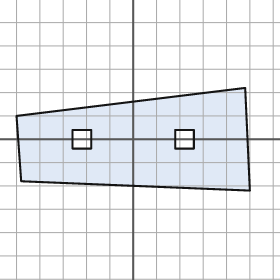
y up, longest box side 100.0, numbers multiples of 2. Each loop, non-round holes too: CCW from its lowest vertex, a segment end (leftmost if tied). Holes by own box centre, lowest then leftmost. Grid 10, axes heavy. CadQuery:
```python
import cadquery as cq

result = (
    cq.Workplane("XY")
    .moveTo(50.0, -22.0)
    .lineTo(48.0, 22.0)
    .lineTo(-50.0, 10.0)
    .lineTo(-48.0, -18.0)
    .close()
    .moveTo(-26.0, -4.0)
    .lineTo(-18.0, -4.0)
    .lineTo(-18.0, 4.0)
    .lineTo(-26.0, 4.0)
    .close()
    .moveTo(18.0, -4.0)
    .lineTo(26.0, -4.0)
    .lineTo(26.0, 4.0)
    .lineTo(18.0, 4.0)
    .close()
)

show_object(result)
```